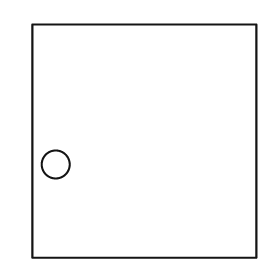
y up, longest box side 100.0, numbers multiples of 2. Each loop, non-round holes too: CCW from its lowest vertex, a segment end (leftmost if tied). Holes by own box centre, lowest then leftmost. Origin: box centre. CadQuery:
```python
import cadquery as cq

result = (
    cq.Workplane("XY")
    .moveTo(-48.0, -50.0)
    .lineTo(48.0, -50.0)
    .lineTo(48.0, 50.0)
    .lineTo(-48.0, 50.0)
    .close()
    .moveTo(-38.0, -10.0)
    .circle(6.0)
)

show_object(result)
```